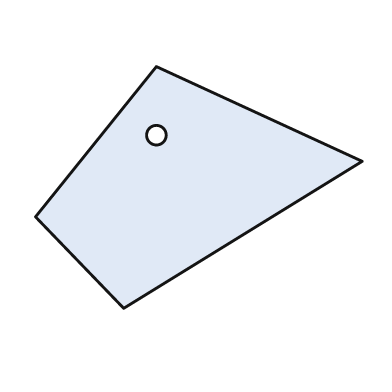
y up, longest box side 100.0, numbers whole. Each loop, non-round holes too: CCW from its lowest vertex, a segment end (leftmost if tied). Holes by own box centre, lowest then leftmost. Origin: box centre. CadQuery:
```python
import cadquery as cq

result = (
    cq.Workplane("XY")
    .moveTo(-23.0, -37.0)
    .lineTo(50.0, 8.0)
    .lineTo(-13.0, 37.0)
    .lineTo(-50.0, -9.0)
    .close()
    .moveTo(-13.0, 16.0)
    .circle(3.0)
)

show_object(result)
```